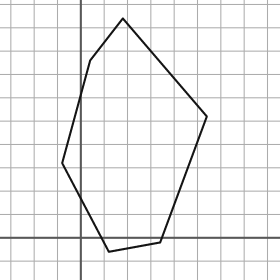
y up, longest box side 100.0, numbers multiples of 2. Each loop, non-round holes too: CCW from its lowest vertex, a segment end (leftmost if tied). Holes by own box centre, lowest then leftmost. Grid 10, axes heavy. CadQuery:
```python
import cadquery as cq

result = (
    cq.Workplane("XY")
    .moveTo(12.0, -6.0)
    .lineTo(34.0, -2.0)
    .lineTo(54.0, 52.0)
    .lineTo(18.0, 94.0)
    .lineTo(4.0, 76.0)
    .lineTo(-8.0, 32.0)
    .close()
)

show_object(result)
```